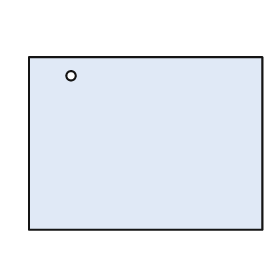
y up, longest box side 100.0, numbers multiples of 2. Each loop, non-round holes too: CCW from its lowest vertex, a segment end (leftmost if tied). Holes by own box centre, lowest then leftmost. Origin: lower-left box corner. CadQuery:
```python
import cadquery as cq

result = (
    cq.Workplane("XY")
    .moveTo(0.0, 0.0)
    .lineTo(100.0, 0.0)
    .lineTo(100.0, 74.0)
    .lineTo(0.0, 74.0)
    .close()
    .moveTo(18.0, 66.0)
    .circle(2.0)
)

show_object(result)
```